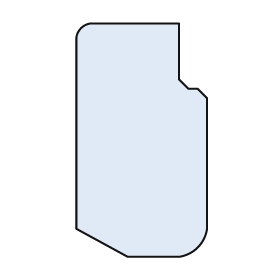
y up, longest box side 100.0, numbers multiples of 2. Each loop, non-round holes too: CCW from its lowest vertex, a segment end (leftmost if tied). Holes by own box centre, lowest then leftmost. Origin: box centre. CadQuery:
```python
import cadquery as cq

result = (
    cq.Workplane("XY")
    .moveTo(-6.0, -50.0)
    .lineTo(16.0, -50.0)
    .threePointArc((24.0, -46.0), (28.0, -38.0))
    .lineTo(28.0, 18.0)
    .lineTo(24.0, 22.0)
    .lineTo(20.0, 22.0)
    .lineTo(16.0, 26.0)
    .lineTo(16.0, 50.0)
    .lineTo(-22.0, 50.0)
    .threePointArc((-26.0, 48.0), (-28.0, 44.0))
    .lineTo(-28.0, -38.0)
    .close()
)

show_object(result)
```